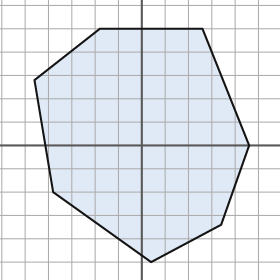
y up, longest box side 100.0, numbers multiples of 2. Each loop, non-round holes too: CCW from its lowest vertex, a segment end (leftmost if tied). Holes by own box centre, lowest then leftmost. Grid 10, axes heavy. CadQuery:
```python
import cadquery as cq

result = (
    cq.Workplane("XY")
    .moveTo(4.0, -50.0)
    .lineTo(34.0, -34.0)
    .lineTo(46.0, 0.0)
    .lineTo(26.0, 50.0)
    .lineTo(-18.0, 50.0)
    .lineTo(-46.0, 28.0)
    .lineTo(-38.0, -20.0)
    .close()
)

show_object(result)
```